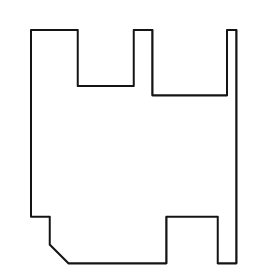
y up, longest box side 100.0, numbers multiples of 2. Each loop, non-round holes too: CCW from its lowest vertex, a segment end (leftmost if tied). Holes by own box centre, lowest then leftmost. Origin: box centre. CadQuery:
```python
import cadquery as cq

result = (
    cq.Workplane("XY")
    .moveTo(-28.0, -50.0)
    .lineTo(14.0, -50.0)
    .lineTo(14.0, -30.0)
    .lineTo(36.0, -30.0)
    .lineTo(36.0, -50.0)
    .lineTo(44.0, -50.0)
    .lineTo(44.0, 50.0)
    .lineTo(40.0, 50.0)
    .lineTo(40.0, 22.0)
    .lineTo(8.0, 22.0)
    .lineTo(8.0, 50.0)
    .lineTo(0.0, 50.0)
    .lineTo(0.0, 26.0)
    .lineTo(-24.0, 26.0)
    .lineTo(-24.0, 50.0)
    .lineTo(-44.0, 50.0)
    .lineTo(-44.0, -30.0)
    .lineTo(-36.0, -30.0)
    .lineTo(-36.0, -42.0)
    .close()
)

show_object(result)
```